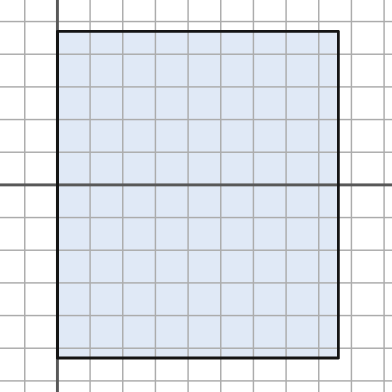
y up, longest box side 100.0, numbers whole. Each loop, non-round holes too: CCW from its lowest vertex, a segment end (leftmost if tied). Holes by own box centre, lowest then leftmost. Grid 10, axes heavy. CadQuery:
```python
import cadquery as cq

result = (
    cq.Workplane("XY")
    .moveTo(0.0, -53.0)
    .lineTo(86.0, -53.0)
    .lineTo(86.0, 47.0)
    .lineTo(0.0, 47.0)
    .close()
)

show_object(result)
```